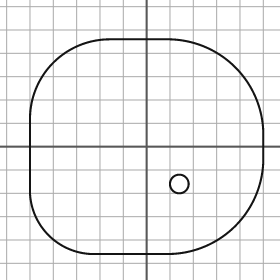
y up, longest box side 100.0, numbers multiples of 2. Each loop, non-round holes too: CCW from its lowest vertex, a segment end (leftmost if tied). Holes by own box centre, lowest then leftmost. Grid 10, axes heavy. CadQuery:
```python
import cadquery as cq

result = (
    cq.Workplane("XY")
    .moveTo(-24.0, -46.0)
    .lineTo(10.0, -46.0)
    .threePointArc((38.0, -34.0), (50.0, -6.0))
    .lineTo(50.0, 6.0)
    .threePointArc((38.0, 34.0), (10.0, 46.0))
    .lineTo(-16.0, 46.0)
    .threePointArc((-40.0, 36.0), (-50.0, 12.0))
    .lineTo(-50.0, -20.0)
    .threePointArc((-42.0, -38.0), (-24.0, -46.0))
    .close()
    .moveTo(14.0, -16.0)
    .circle(4.0)
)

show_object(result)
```